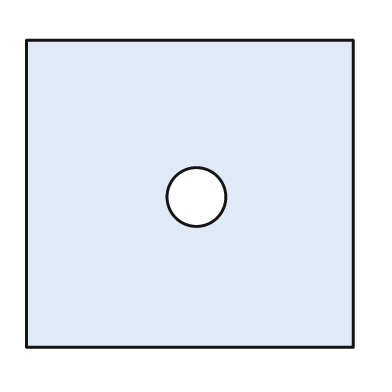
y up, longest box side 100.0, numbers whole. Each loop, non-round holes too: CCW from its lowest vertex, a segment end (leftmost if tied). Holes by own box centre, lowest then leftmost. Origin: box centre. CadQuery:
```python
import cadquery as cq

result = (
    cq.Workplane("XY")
    .moveTo(-50.0, -47.0)
    .lineTo(50.0, -47.0)
    .lineTo(50.0, 47.0)
    .lineTo(-50.0, 47.0)
    .close()
    .moveTo(2.0, -1.0)
    .circle(9.0)
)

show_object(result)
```